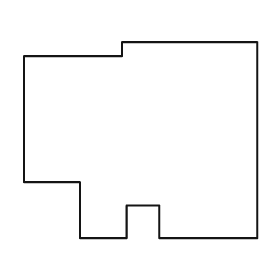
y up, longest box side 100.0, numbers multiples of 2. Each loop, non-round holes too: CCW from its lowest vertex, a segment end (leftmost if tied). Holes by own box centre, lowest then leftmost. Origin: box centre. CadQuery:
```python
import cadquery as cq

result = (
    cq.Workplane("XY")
    .moveTo(-26.0, -42.0)
    .lineTo(-6.0, -42.0)
    .lineTo(-6.0, -28.0)
    .lineTo(8.0, -28.0)
    .lineTo(8.0, -42.0)
    .lineTo(50.0, -42.0)
    .lineTo(50.0, 42.0)
    .lineTo(-8.0, 42.0)
    .lineTo(-8.0, 36.0)
    .lineTo(-50.0, 36.0)
    .lineTo(-50.0, -18.0)
    .lineTo(-26.0, -18.0)
    .close()
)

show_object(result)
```